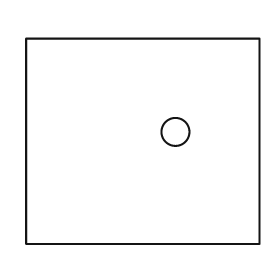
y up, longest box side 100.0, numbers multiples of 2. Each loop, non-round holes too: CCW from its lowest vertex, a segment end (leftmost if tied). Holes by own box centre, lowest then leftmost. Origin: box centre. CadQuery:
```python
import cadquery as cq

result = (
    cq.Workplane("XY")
    .moveTo(-50.0, -44.0)
    .lineTo(50.0, -44.0)
    .lineTo(50.0, 44.0)
    .lineTo(-50.0, 44.0)
    .close()
    .moveTo(14.0, 4.0)
    .circle(6.0)
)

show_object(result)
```